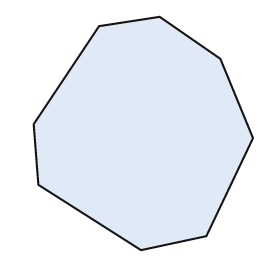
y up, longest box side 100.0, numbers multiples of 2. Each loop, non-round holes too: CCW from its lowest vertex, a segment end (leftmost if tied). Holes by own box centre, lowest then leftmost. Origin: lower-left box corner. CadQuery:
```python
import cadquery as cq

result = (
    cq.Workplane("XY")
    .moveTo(46.0, 0.0)
    .lineTo(74.0, 6.0)
    .lineTo(94.0, 48.0)
    .lineTo(80.0, 82.0)
    .lineTo(54.0, 100.0)
    .lineTo(28.0, 96.0)
    .lineTo(0.0, 54.0)
    .lineTo(2.0, 28.0)
    .close()
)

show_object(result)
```